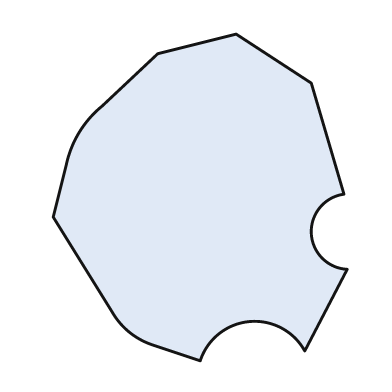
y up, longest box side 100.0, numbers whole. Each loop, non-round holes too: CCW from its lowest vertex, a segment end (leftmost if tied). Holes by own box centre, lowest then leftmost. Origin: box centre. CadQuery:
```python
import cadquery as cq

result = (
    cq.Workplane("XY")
    .moveTo(0.0, -50.0)
    .threePointArc((15.0, -38.0), (32.0, -47.0))
    .lineTo(45.0, -22.0)
    .threePointArc((34.0, -11.0), (44.0, 1.0))
    .lineTo(34.0, 35.0)
    .lineTo(11.0, 50.0)
    .lineTo(-13.0, 44.0)
    .lineTo(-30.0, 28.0)
    .threePointArc((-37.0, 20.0), (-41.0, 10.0))
    .lineTo(-45.0, -6.0)
    .lineTo(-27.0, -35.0)
    .threePointArc((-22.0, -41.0), (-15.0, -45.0))
    .close()
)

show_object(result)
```